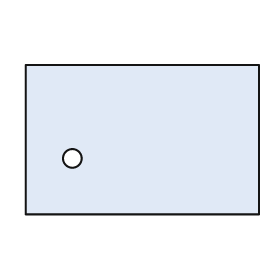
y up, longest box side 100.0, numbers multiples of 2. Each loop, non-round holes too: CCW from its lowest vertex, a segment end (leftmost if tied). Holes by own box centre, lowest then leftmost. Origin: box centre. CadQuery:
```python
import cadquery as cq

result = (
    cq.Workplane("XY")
    .moveTo(-50.0, -32.0)
    .lineTo(50.0, -32.0)
    .lineTo(50.0, 32.0)
    .lineTo(-50.0, 32.0)
    .close()
    .moveTo(-30.0, -8.0)
    .circle(4.0)
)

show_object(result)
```